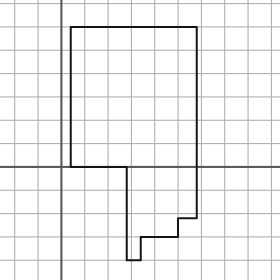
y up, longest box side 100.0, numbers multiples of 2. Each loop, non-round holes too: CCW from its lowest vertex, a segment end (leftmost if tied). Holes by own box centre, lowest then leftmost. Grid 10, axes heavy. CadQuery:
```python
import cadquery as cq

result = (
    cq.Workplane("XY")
    .moveTo(28.0, -40.0)
    .lineTo(34.0, -40.0)
    .lineTo(34.0, -30.0)
    .lineTo(50.0, -30.0)
    .lineTo(50.0, -22.0)
    .lineTo(58.0, -22.0)
    .lineTo(58.0, 60.0)
    .lineTo(4.0, 60.0)
    .lineTo(4.0, 0.0)
    .lineTo(28.0, 0.0)
    .close()
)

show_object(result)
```